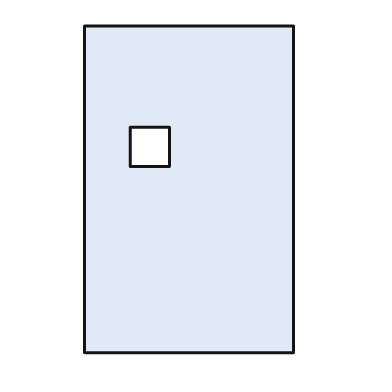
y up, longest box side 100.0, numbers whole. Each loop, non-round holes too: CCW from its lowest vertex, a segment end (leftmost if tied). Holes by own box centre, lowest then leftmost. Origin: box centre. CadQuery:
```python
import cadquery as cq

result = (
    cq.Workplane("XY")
    .moveTo(-32.0, -50.0)
    .lineTo(32.0, -50.0)
    .lineTo(32.0, 50.0)
    .lineTo(-32.0, 50.0)
    .close()
    .moveTo(-18.0, 7.0)
    .lineTo(-6.0, 7.0)
    .lineTo(-6.0, 19.0)
    .lineTo(-18.0, 19.0)
    .close()
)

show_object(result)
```